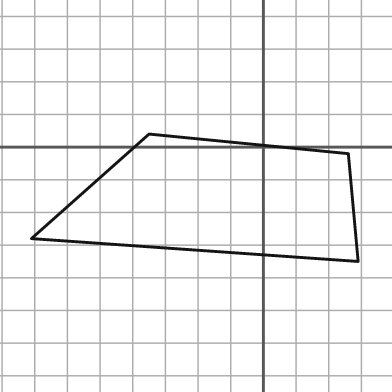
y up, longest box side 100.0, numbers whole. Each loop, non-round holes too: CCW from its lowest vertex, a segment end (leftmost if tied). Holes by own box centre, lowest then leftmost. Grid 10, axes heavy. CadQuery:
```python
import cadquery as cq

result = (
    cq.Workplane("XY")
    .moveTo(29.0, -35.0)
    .lineTo(26.0, -2.0)
    .lineTo(-35.0, 4.0)
    .lineTo(-71.0, -28.0)
    .close()
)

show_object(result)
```